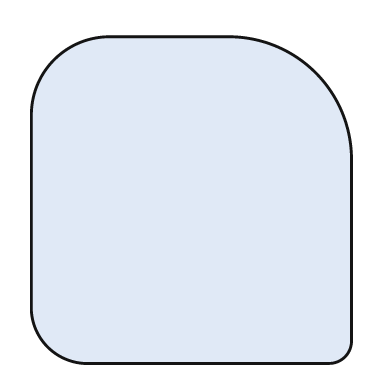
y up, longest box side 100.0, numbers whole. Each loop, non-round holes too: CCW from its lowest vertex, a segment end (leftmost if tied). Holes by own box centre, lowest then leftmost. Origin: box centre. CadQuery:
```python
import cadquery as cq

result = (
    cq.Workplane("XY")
    .moveTo(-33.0, -50.0)
    .lineTo(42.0, -50.0)
    .threePointArc((47.0, -48.0), (49.0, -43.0))
    .lineTo(49.0, 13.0)
    .threePointArc((38.0, 39.0), (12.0, 50.0))
    .lineTo(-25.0, 50.0)
    .threePointArc((-42.0, 43.0), (-49.0, 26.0))
    .lineTo(-49.0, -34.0)
    .threePointArc((-44.0, -45.0), (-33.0, -50.0))
    .close()
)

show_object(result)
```